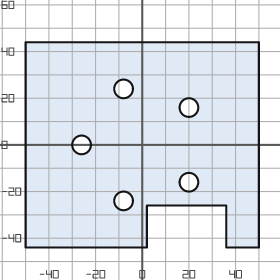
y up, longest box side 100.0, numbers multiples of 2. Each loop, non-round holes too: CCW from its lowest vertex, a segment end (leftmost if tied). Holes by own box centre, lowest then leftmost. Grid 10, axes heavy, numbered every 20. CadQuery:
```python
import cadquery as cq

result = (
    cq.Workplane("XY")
    .moveTo(-50.0, -44.0)
    .lineTo(2.0, -44.0)
    .lineTo(2.0, -26.0)
    .lineTo(36.0, -26.0)
    .lineTo(36.0, -44.0)
    .lineTo(50.0, -44.0)
    .lineTo(50.0, 44.0)
    .lineTo(-50.0, 44.0)
    .close()
    .moveTo(-8.0, -24.0)
    .circle(4.0)
    .moveTo(20.0, -16.0)
    .circle(4.0)
    .moveTo(-26.0, 0.0)
    .circle(4.0)
    .moveTo(20.0, 16.0)
    .circle(4.0)
    .moveTo(-8.0, 24.0)
    .circle(4.0)
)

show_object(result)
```